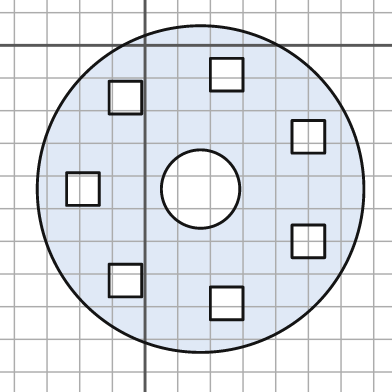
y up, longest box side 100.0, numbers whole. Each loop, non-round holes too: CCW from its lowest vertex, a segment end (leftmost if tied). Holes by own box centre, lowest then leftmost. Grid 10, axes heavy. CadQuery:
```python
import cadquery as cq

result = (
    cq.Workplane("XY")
    .moveTo(17.0, -44.0)
    .circle(50.0)
    .moveTo(20.0, -84.0)
    .lineTo(30.0, -84.0)
    .lineTo(30.0, -74.0)
    .lineTo(20.0, -74.0)
    .close()
    .moveTo(-11.0, -77.0)
    .lineTo(-1.0, -77.0)
    .lineTo(-1.0, -67.0)
    .lineTo(-11.0, -67.0)
    .close()
    .moveTo(45.0, -65.0)
    .lineTo(55.0, -65.0)
    .lineTo(55.0, -55.0)
    .lineTo(45.0, -55.0)
    .close()
    .moveTo(-24.0, -49.0)
    .lineTo(-14.0, -49.0)
    .lineTo(-14.0, -39.0)
    .lineTo(-24.0, -39.0)
    .close()
    .moveTo(17.0, -44.0)
    .circle(12.0)
    .moveTo(45.0, -33.0)
    .lineTo(55.0, -33.0)
    .lineTo(55.0, -23.0)
    .lineTo(45.0, -23.0)
    .close()
    .moveTo(-11.0, -21.0)
    .lineTo(-1.0, -21.0)
    .lineTo(-1.0, -11.0)
    .lineTo(-11.0, -11.0)
    .close()
    .moveTo(20.0, -14.0)
    .lineTo(30.0, -14.0)
    .lineTo(30.0, -4.0)
    .lineTo(20.0, -4.0)
    .close()
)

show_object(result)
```